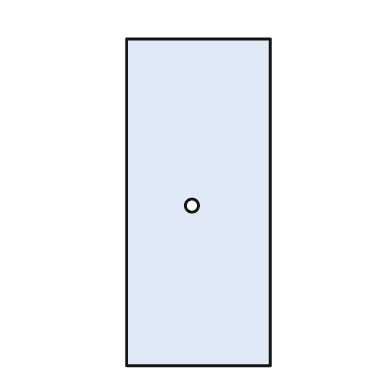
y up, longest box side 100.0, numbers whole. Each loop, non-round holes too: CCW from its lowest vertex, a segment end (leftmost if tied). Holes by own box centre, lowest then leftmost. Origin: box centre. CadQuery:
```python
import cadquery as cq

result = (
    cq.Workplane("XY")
    .moveTo(-22.0, -50.0)
    .lineTo(22.0, -50.0)
    .lineTo(22.0, 50.0)
    .lineTo(-22.0, 50.0)
    .close()
    .moveTo(-2.0, -1.0)
    .circle(2.0)
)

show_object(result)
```